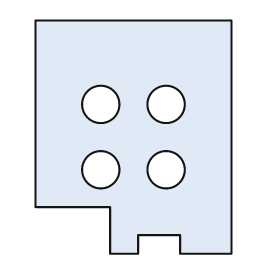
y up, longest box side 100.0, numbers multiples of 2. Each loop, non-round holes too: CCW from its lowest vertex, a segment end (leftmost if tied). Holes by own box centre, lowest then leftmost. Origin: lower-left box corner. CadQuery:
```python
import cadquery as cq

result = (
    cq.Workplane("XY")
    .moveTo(32.0, 0.0)
    .lineTo(44.0, 0.0)
    .lineTo(44.0, 8.0)
    .lineTo(62.0, 8.0)
    .lineTo(62.0, 0.0)
    .lineTo(84.0, 0.0)
    .lineTo(84.0, 100.0)
    .lineTo(0.0, 100.0)
    .lineTo(0.0, 20.0)
    .lineTo(32.0, 20.0)
    .close()
    .moveTo(28.0, 36.0)
    .circle(8.0)
    .moveTo(56.0, 36.0)
    .circle(8.0)
    .moveTo(28.0, 64.0)
    .circle(8.0)
    .moveTo(56.0, 64.0)
    .circle(8.0)
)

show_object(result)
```